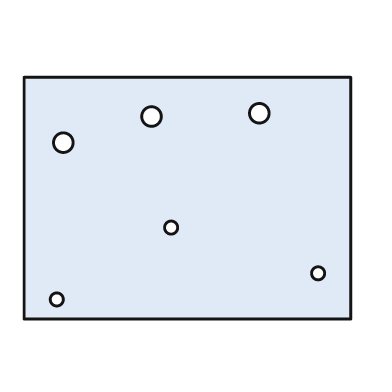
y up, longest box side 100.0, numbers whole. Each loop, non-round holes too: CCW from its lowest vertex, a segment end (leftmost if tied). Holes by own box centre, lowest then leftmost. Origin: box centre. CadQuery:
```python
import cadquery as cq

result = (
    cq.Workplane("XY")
    .moveTo(-50.0, -37.0)
    .lineTo(50.0, -37.0)
    .lineTo(50.0, 37.0)
    .lineTo(-50.0, 37.0)
    .close()
    .moveTo(-40.0, -31.0)
    .circle(2.0)
    .moveTo(40.0, -23.0)
    .circle(2.0)
    .moveTo(-5.0, -9.0)
    .circle(2.0)
    .moveTo(-38.0, 17.0)
    .circle(3.0)
    .moveTo(-11.0, 25.0)
    .circle(3.0)
    .moveTo(22.0, 26.0)
    .circle(3.0)
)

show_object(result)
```